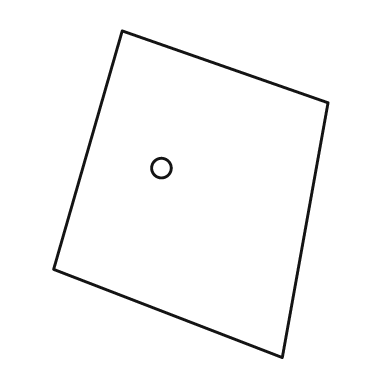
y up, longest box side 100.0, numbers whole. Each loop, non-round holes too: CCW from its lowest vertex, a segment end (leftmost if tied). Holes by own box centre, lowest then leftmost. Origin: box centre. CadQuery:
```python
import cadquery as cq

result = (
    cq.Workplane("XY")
    .moveTo(28.0, -50.0)
    .lineTo(42.0, 28.0)
    .lineTo(-21.0, 50.0)
    .lineTo(-42.0, -23.0)
    .close()
    .moveTo(-9.0, 8.0)
    .circle(3.0)
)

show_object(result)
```